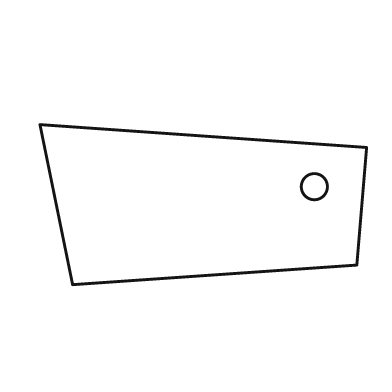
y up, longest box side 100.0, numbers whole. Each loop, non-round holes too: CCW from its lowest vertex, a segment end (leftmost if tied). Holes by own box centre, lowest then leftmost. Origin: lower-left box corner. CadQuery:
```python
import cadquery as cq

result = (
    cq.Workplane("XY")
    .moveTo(10.0, 0.0)
    .lineTo(97.0, 6.0)
    .lineTo(100.0, 42.0)
    .lineTo(0.0, 49.0)
    .close()
    .moveTo(84.0, 30.0)
    .circle(4.0)
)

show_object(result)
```